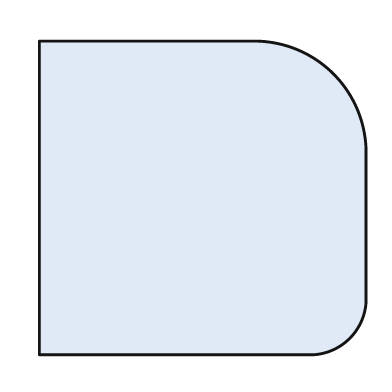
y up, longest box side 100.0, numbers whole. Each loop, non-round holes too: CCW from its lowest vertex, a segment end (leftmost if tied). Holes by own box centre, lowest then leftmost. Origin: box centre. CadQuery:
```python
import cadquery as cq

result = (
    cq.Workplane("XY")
    .moveTo(-50.0, -48.0)
    .lineTo(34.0, -48.0)
    .threePointArc((45.0, -43.0), (50.0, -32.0))
    .lineTo(50.0, 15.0)
    .threePointArc((40.0, 38.0), (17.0, 48.0))
    .lineTo(-50.0, 48.0)
    .close()
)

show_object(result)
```